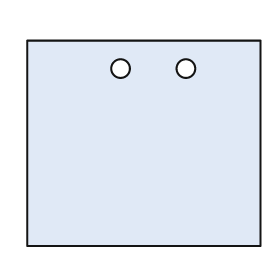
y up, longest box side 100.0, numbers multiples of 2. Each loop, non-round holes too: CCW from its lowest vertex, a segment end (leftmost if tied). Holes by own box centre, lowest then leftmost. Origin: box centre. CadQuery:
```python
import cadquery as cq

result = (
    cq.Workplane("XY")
    .moveTo(-50.0, -44.0)
    .lineTo(50.0, -44.0)
    .lineTo(50.0, 44.0)
    .lineTo(-50.0, 44.0)
    .close()
    .moveTo(-10.0, 32.0)
    .circle(4.0)
    .moveTo(18.0, 32.0)
    .circle(4.0)
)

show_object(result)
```